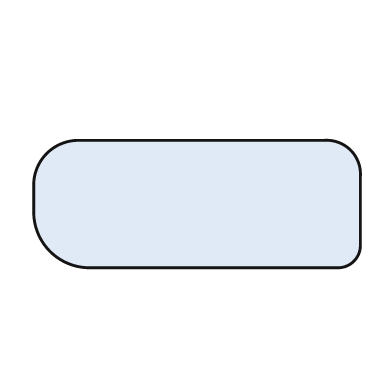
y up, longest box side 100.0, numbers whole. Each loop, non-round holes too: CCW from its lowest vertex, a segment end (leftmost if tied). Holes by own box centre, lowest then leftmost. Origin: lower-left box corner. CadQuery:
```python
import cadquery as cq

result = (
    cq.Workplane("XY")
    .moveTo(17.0, 0.0)
    .lineTo(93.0, 0.0)
    .threePointArc((98.0, 2.0), (100.0, 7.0))
    .lineTo(100.0, 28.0)
    .threePointArc((97.0, 36.0), (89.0, 39.0))
    .lineTo(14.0, 39.0)
    .threePointArc((4.0, 35.0), (0.0, 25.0))
    .lineTo(0.0, 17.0)
    .threePointArc((5.0, 5.0), (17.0, 0.0))
    .close()
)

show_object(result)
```